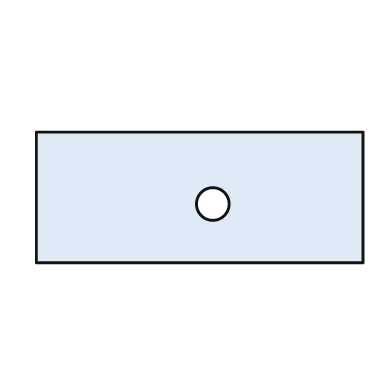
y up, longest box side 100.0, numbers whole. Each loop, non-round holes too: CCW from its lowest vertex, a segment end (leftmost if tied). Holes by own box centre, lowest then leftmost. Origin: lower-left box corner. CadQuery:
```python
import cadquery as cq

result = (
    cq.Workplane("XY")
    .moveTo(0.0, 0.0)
    .lineTo(100.0, 0.0)
    .lineTo(100.0, 40.0)
    .lineTo(0.0, 40.0)
    .close()
    .moveTo(54.0, 18.0)
    .circle(5.0)
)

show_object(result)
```